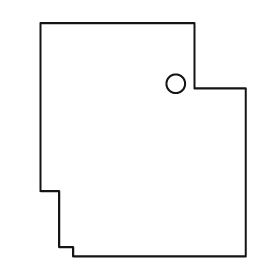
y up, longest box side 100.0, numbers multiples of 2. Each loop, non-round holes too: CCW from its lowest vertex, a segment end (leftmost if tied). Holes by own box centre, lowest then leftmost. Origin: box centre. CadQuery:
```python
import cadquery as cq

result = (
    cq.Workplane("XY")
    .moveTo(-30.0, -50.0)
    .lineTo(44.0, -50.0)
    .lineTo(44.0, 22.0)
    .lineTo(22.0, 22.0)
    .lineTo(22.0, 50.0)
    .lineTo(-44.0, 50.0)
    .lineTo(-44.0, -22.0)
    .lineTo(-36.0, -22.0)
    .lineTo(-36.0, -46.0)
    .lineTo(-30.0, -46.0)
    .close()
    .moveTo(14.0, 24.0)
    .circle(4.0)
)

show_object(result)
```